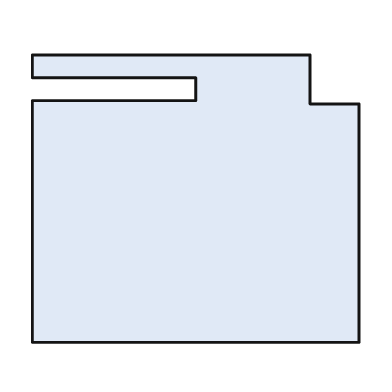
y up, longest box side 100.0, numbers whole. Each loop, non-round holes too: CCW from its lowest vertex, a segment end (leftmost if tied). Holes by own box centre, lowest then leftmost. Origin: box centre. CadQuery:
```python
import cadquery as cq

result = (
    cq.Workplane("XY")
    .moveTo(-50.0, -44.0)
    .lineTo(50.0, -44.0)
    .lineTo(50.0, 29.0)
    .lineTo(35.0, 29.0)
    .lineTo(35.0, 44.0)
    .lineTo(-50.0, 44.0)
    .lineTo(-50.0, 37.0)
    .lineTo(0.0, 37.0)
    .lineTo(0.0, 30.0)
    .lineTo(-50.0, 30.0)
    .close()
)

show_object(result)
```